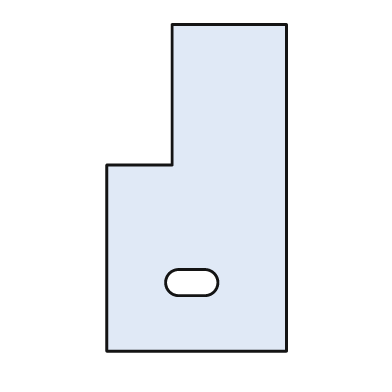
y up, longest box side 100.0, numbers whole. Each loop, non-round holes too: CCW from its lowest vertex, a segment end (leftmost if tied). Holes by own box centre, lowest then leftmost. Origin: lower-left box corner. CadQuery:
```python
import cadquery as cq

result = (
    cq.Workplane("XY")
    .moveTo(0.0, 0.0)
    .lineTo(55.0, 0.0)
    .lineTo(55.0, 100.0)
    .lineTo(20.0, 100.0)
    .lineTo(20.0, 57.0)
    .lineTo(0.0, 57.0)
    .close()
    .moveTo(22.0, 17.0)
    .lineTo(30.0, 17.0)
    .threePointArc((34.0, 21.0), (30.0, 25.0))
    .lineTo(22.0, 25.0)
    .threePointArc((18.0, 21.0), (22.0, 17.0))
    .close()
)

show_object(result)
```